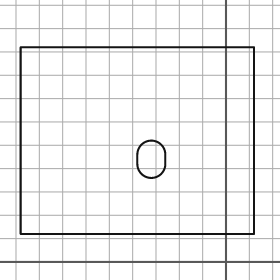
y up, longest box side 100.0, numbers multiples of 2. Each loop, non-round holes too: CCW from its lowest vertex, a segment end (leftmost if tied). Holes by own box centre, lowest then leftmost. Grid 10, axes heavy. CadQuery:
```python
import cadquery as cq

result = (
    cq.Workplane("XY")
    .moveTo(-88.0, 12.0)
    .lineTo(12.0, 12.0)
    .lineTo(12.0, 92.0)
    .lineTo(-88.0, 92.0)
    .close()
    .moveTo(-38.0, 42.0)
    .threePointArc((-32.0, 36.0), (-26.0, 42.0))
    .lineTo(-26.0, 46.0)
    .threePointArc((-32.0, 52.0), (-38.0, 46.0))
    .close()
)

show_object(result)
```